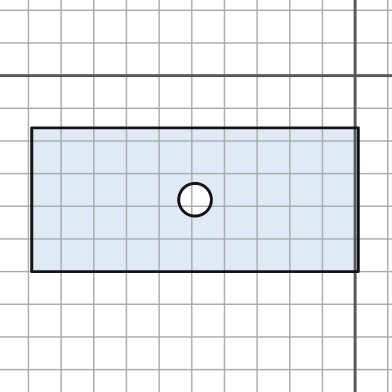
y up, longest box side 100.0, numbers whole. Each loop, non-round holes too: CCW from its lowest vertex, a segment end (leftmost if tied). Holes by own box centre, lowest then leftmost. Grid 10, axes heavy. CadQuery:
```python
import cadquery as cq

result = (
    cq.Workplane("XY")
    .moveTo(-99.0, -60.0)
    .lineTo(1.0, -60.0)
    .lineTo(1.0, -16.0)
    .lineTo(-99.0, -16.0)
    .close()
    .moveTo(-49.0, -38.0)
    .circle(5.0)
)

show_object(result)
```